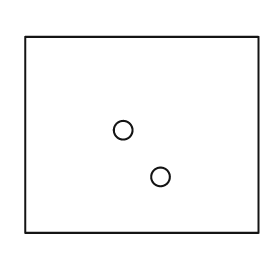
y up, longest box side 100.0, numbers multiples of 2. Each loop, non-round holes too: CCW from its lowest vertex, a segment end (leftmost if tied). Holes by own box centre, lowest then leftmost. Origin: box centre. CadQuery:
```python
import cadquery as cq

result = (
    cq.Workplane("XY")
    .moveTo(-50.0, -42.0)
    .lineTo(50.0, -42.0)
    .lineTo(50.0, 42.0)
    .lineTo(-50.0, 42.0)
    .close()
    .moveTo(8.0, -18.0)
    .circle(4.0)
    .moveTo(-8.0, 2.0)
    .circle(4.0)
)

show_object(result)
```